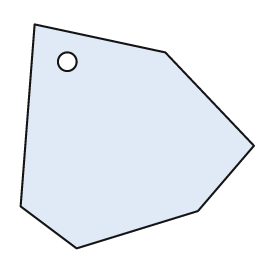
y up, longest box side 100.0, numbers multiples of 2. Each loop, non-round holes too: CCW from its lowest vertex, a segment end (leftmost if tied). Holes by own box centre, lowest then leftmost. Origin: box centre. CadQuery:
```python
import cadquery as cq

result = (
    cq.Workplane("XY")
    .moveTo(-26.0, -48.0)
    .lineTo(26.0, -32.0)
    .lineTo(50.0, -4.0)
    .lineTo(12.0, 36.0)
    .lineTo(-44.0, 48.0)
    .lineTo(-50.0, -30.0)
    .close()
    .moveTo(-30.0, 32.0)
    .circle(4.0)
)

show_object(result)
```